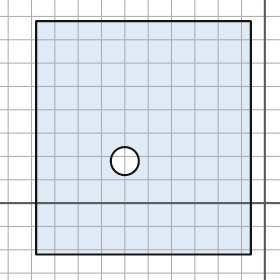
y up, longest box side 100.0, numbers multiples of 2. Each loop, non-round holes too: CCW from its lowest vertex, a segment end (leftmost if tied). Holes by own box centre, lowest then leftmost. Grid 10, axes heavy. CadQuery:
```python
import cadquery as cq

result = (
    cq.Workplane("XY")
    .moveTo(-98.0, -22.0)
    .lineTo(-6.0, -22.0)
    .lineTo(-6.0, 78.0)
    .lineTo(-98.0, 78.0)
    .close()
    .moveTo(-60.0, 18.0)
    .circle(6.0)
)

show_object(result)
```